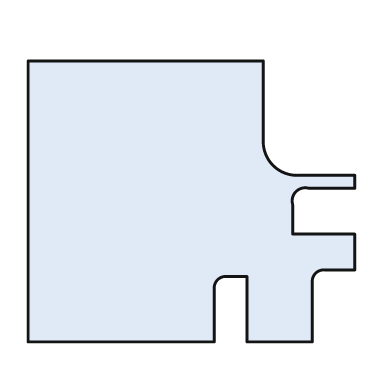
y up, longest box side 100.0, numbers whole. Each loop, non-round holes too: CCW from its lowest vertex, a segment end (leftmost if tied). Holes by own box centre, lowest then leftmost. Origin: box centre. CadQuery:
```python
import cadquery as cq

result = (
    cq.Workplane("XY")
    .moveTo(-50.0, -43.0)
    .lineTo(7.0, -43.0)
    .lineTo(7.0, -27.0)
    .threePointArc((8.0, -24.0), (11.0, -23.0))
    .lineTo(17.0, -23.0)
    .lineTo(17.0, -43.0)
    .lineTo(37.0, -43.0)
    .lineTo(37.0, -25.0)
    .threePointArc((38.0, -22.0), (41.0, -21.0))
    .lineTo(50.0, -21.0)
    .lineTo(50.0, -10.0)
    .lineTo(31.0, -10.0)
    .lineTo(31.0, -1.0)
    .threePointArc((32.0, 3.0), (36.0, 4.0))
    .lineTo(50.0, 4.0)
    .lineTo(50.0, 8.0)
    .lineTo(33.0, 8.0)
    .threePointArc((25.0, 11.0), (22.0, 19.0))
    .lineTo(22.0, 43.0)
    .lineTo(-50.0, 43.0)
    .close()
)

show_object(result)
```